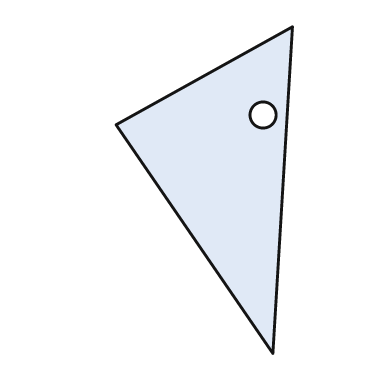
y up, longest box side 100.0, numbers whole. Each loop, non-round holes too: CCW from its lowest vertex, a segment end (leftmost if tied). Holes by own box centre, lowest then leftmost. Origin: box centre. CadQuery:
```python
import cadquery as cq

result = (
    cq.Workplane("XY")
    .moveTo(21.0, -50.0)
    .lineTo(27.0, 50.0)
    .lineTo(-27.0, 20.0)
    .close()
    .moveTo(18.0, 23.0)
    .circle(4.0)
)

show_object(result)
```